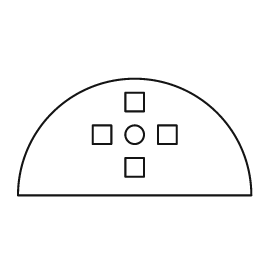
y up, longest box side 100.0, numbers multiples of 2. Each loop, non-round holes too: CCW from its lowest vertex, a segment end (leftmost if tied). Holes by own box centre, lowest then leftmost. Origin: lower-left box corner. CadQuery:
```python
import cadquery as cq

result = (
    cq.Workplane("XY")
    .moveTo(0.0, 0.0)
    .lineTo(100.0, 0.0)
    .threePointArc((50.0, 50.0), (0.0, 0.0))
    .close()
    .moveTo(46.0, 8.0)
    .lineTo(54.0, 8.0)
    .lineTo(54.0, 16.0)
    .lineTo(46.0, 16.0)
    .close()
    .moveTo(32.0, 22.0)
    .lineTo(40.0, 22.0)
    .lineTo(40.0, 30.0)
    .lineTo(32.0, 30.0)
    .close()
    .moveTo(50.0, 26.0)
    .circle(4.0)
    .moveTo(60.0, 22.0)
    .lineTo(68.0, 22.0)
    .lineTo(68.0, 30.0)
    .lineTo(60.0, 30.0)
    .close()
    .moveTo(46.0, 36.0)
    .lineTo(54.0, 36.0)
    .lineTo(54.0, 44.0)
    .lineTo(46.0, 44.0)
    .close()
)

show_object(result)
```